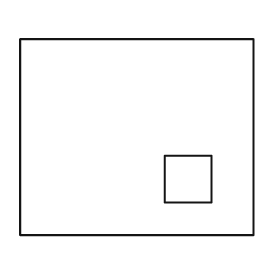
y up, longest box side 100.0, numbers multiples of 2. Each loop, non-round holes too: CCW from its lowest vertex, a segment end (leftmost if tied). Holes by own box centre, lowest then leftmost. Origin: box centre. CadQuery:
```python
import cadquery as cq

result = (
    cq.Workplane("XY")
    .moveTo(-50.0, -42.0)
    .lineTo(50.0, -42.0)
    .lineTo(50.0, 42.0)
    .lineTo(-50.0, 42.0)
    .close()
    .moveTo(12.0, -28.0)
    .lineTo(32.0, -28.0)
    .lineTo(32.0, -8.0)
    .lineTo(12.0, -8.0)
    .close()
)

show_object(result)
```